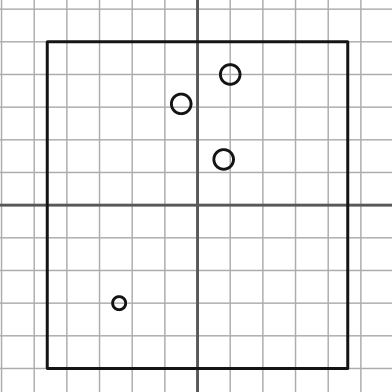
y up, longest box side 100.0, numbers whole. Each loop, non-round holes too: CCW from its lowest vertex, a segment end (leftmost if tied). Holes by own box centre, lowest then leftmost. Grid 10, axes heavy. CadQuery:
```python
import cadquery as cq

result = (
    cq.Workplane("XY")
    .moveTo(-46.0, -50.0)
    .lineTo(46.0, -50.0)
    .lineTo(46.0, 50.0)
    .lineTo(-46.0, 50.0)
    .close()
    .moveTo(-24.0, -30.0)
    .circle(2.0)
    .moveTo(8.0, 14.0)
    .circle(3.0)
    .moveTo(-5.0, 31.0)
    .circle(3.0)
    .moveTo(10.0, 40.0)
    .circle(3.0)
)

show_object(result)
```